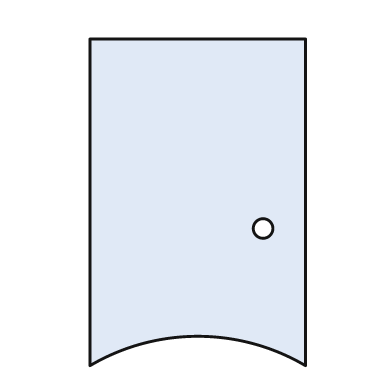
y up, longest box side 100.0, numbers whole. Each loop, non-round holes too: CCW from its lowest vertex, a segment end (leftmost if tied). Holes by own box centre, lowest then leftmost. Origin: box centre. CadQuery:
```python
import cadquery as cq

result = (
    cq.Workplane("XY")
    .moveTo(-33.0, -50.0)
    .threePointArc((0.0, -41.0), (33.0, -50.0))
    .lineTo(33.0, 50.0)
    .lineTo(-33.0, 50.0)
    .close()
    .moveTo(20.0, -8.0)
    .circle(3.0)
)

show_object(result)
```